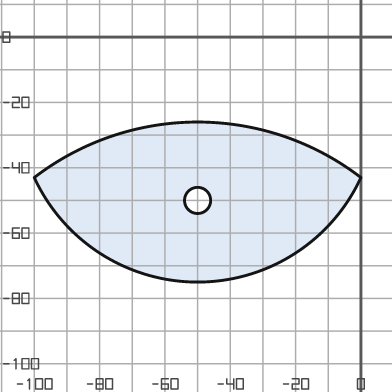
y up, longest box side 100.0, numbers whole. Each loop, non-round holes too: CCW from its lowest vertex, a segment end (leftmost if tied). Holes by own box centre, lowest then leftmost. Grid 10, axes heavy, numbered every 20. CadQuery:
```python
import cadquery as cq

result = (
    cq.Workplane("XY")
    .moveTo(-100.0, -43.0)
    .threePointArc((-50.0, -75.0), (0.0, -43.0))
    .threePointArc((-50.0, -26.0), (-100.0, -43.0))
    .close()
    .moveTo(-50.0, -50.0)
    .circle(4.0)
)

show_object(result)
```